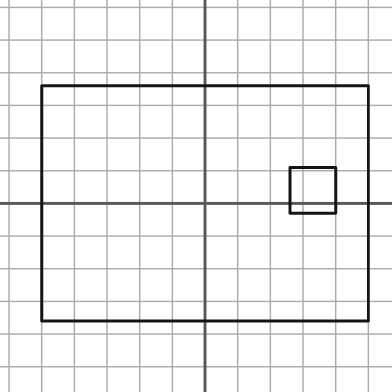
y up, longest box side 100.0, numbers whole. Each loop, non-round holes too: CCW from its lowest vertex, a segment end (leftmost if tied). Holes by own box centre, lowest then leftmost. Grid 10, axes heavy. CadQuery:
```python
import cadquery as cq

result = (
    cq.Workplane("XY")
    .moveTo(-50.0, -36.0)
    .lineTo(50.0, -36.0)
    .lineTo(50.0, 36.0)
    .lineTo(-50.0, 36.0)
    .close()
    .moveTo(26.0, -3.0)
    .lineTo(40.0, -3.0)
    .lineTo(40.0, 11.0)
    .lineTo(26.0, 11.0)
    .close()
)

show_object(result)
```